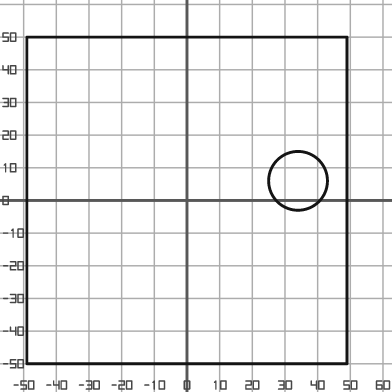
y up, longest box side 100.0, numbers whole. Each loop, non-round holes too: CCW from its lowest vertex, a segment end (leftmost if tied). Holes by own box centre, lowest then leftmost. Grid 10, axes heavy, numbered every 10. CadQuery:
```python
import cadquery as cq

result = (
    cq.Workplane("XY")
    .moveTo(-49.0, -50.0)
    .lineTo(49.0, -50.0)
    .lineTo(49.0, 50.0)
    .lineTo(-49.0, 50.0)
    .close()
    .moveTo(34.0, 6.0)
    .circle(9.0)
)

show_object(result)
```